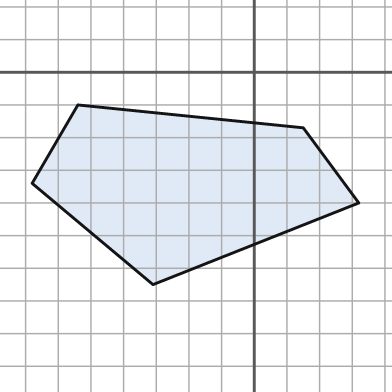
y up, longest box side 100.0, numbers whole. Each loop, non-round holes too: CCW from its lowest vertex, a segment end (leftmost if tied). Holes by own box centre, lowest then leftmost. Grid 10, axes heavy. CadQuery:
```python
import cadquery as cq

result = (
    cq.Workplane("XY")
    .moveTo(-31.0, -65.0)
    .lineTo(32.0, -40.0)
    .lineTo(15.0, -17.0)
    .lineTo(-54.0, -10.0)
    .lineTo(-68.0, -34.0)
    .close()
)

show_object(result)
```